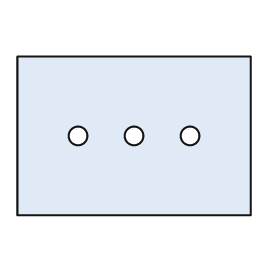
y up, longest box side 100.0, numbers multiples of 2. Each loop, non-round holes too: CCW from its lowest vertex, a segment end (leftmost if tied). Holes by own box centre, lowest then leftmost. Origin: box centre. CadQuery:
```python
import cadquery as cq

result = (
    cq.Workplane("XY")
    .moveTo(-50.0, -34.0)
    .lineTo(50.0, -34.0)
    .lineTo(50.0, 34.0)
    .lineTo(-50.0, 34.0)
    .close()
    .moveTo(-24.0, 0.0)
    .circle(4.0)
    .moveTo(0.0, 0.0)
    .circle(4.0)
    .moveTo(24.0, 0.0)
    .circle(4.0)
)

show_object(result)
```